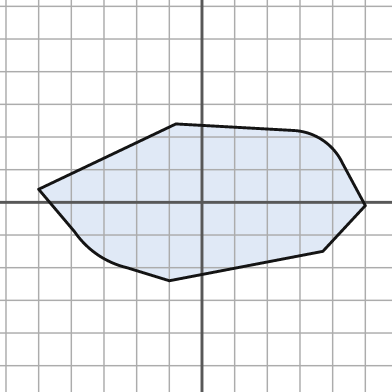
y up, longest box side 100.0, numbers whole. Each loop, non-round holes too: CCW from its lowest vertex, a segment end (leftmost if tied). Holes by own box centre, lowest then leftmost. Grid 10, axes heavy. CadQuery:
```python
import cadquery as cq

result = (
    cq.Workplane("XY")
    .moveTo(-10.0, -24.0)
    .lineTo(37.0, -15.0)
    .lineTo(50.0, -1.0)
    .lineTo(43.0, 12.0)
    .threePointArc((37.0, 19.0), (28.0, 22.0))
    .lineTo(-8.0, 24.0)
    .lineTo(-50.0, 4.0)
    .lineTo(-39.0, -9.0)
    .threePointArc((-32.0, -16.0), (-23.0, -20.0))
    .close()
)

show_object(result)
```